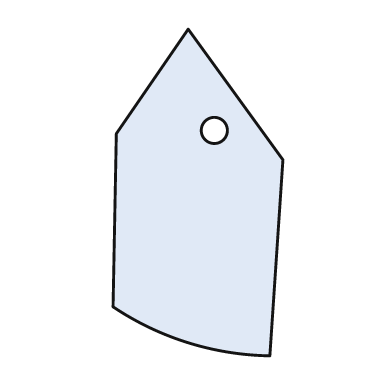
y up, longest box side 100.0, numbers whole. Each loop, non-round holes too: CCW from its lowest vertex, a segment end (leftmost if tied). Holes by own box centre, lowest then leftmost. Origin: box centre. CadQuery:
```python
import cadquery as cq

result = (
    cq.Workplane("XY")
    .moveTo(22.0, -50.0)
    .lineTo(26.0, 10.0)
    .lineTo(-3.0, 50.0)
    .lineTo(-25.0, 18.0)
    .lineTo(-26.0, -35.0)
    .threePointArc((-3.0, -46.0), (22.0, -50.0))
    .close()
    .moveTo(5.0, 19.0)
    .circle(4.0)
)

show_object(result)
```